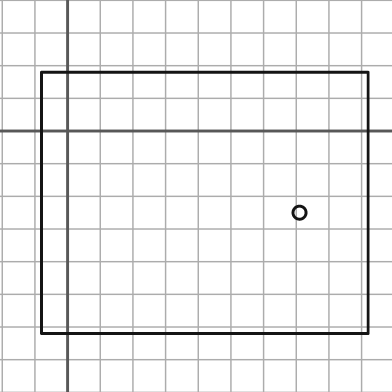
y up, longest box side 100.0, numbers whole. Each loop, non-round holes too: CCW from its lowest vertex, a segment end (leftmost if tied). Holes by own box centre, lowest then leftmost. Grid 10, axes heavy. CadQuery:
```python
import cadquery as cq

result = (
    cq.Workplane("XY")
    .moveTo(-8.0, -62.0)
    .lineTo(92.0, -62.0)
    .lineTo(92.0, 18.0)
    .lineTo(-8.0, 18.0)
    .close()
    .moveTo(71.0, -25.0)
    .circle(2.0)
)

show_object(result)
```